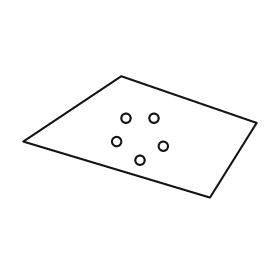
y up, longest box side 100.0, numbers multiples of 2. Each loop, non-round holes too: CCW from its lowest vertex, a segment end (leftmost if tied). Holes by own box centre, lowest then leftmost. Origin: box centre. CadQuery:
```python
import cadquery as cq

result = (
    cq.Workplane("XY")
    .moveTo(30.0, -26.0)
    .lineTo(50.0, 6.0)
    .lineTo(-8.0, 26.0)
    .lineTo(-50.0, -2.0)
    .close()
    .moveTo(0.0, -10.0)
    .circle(2.0)
    .moveTo(10.0, -4.0)
    .circle(2.0)
    .moveTo(-10.0, -2.0)
    .circle(2.0)
    .moveTo(-6.0, 8.0)
    .circle(2.0)
    .moveTo(6.0, 8.0)
    .circle(2.0)
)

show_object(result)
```